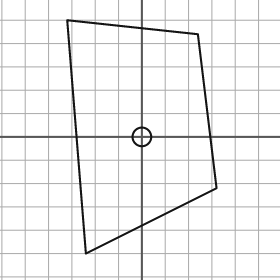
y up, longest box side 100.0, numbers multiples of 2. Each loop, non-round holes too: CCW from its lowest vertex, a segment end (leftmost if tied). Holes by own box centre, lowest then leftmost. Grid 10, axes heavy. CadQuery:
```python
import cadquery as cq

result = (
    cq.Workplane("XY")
    .moveTo(-24.0, -50.0)
    .lineTo(32.0, -22.0)
    .lineTo(24.0, 44.0)
    .lineTo(-32.0, 50.0)
    .close()
    .moveTo(0.0, 0.0)
    .circle(4.0)
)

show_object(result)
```